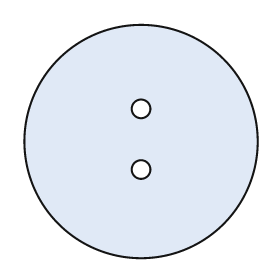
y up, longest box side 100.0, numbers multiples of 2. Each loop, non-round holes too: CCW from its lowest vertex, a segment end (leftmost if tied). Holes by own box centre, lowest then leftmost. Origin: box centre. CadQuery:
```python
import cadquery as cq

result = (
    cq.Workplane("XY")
    .moveTo(0.0, 0.0)
    .circle(50.0)
    .moveTo(0.0, -12.0)
    .circle(4.0)
    .moveTo(0.0, 14.0)
    .circle(4.0)
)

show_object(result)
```